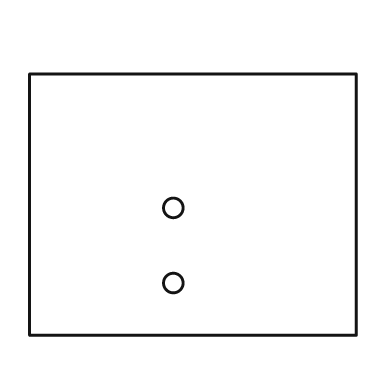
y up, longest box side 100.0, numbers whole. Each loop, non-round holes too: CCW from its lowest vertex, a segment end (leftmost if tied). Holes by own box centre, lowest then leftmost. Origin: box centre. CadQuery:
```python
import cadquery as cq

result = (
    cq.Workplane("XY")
    .moveTo(-50.0, -40.0)
    .lineTo(50.0, -40.0)
    .lineTo(50.0, 40.0)
    .lineTo(-50.0, 40.0)
    .close()
    .moveTo(-6.0, -24.0)
    .circle(3.0)
    .moveTo(-6.0, -1.0)
    .circle(3.0)
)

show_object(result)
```